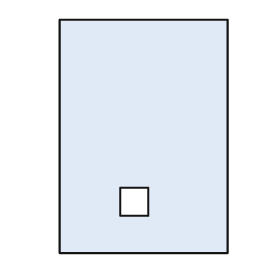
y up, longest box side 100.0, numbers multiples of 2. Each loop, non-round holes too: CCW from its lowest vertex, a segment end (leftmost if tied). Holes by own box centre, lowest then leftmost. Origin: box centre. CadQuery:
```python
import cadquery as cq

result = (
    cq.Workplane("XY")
    .moveTo(-36.0, -50.0)
    .lineTo(36.0, -50.0)
    .lineTo(36.0, 50.0)
    .lineTo(-36.0, 50.0)
    .close()
    .moveTo(-10.0, -34.0)
    .lineTo(2.0, -34.0)
    .lineTo(2.0, -22.0)
    .lineTo(-10.0, -22.0)
    .close()
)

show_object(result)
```